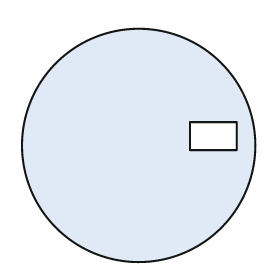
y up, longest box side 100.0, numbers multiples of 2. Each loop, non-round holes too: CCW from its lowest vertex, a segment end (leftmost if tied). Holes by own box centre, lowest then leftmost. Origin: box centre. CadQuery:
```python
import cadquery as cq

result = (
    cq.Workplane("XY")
    .moveTo(0.0, 0.0)
    .circle(50.0)
    .moveTo(22.0, -2.0)
    .lineTo(42.0, -2.0)
    .lineTo(42.0, 10.0)
    .lineTo(22.0, 10.0)
    .close()
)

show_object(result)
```